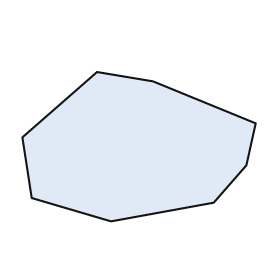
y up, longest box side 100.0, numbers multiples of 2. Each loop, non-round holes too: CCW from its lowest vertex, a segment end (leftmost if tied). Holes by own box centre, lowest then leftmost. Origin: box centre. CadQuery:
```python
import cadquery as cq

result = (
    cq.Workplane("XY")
    .moveTo(-12.0, -32.0)
    .lineTo(32.0, -24.0)
    .lineTo(46.0, -8.0)
    .lineTo(50.0, 10.0)
    .lineTo(6.0, 28.0)
    .lineTo(-18.0, 32.0)
    .lineTo(-50.0, 4.0)
    .lineTo(-46.0, -22.0)
    .close()
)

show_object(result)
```